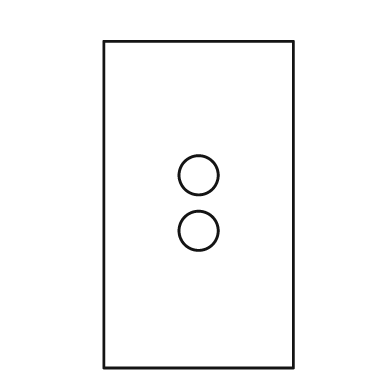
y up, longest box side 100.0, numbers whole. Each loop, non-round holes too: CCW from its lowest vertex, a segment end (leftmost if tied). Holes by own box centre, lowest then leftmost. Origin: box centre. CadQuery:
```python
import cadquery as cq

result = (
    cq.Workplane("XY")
    .moveTo(-29.0, -50.0)
    .lineTo(29.0, -50.0)
    .lineTo(29.0, 50.0)
    .lineTo(-29.0, 50.0)
    .close()
    .moveTo(0.0, -8.0)
    .circle(6.0)
    .moveTo(0.0, 9.0)
    .circle(6.0)
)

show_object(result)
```